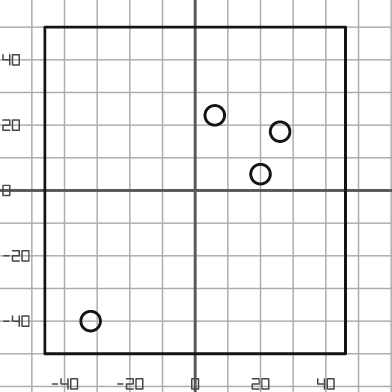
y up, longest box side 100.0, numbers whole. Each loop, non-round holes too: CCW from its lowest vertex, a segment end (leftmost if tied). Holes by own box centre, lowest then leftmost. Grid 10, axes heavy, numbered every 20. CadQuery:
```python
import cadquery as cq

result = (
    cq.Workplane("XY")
    .moveTo(-46.0, -50.0)
    .lineTo(46.0, -50.0)
    .lineTo(46.0, 50.0)
    .lineTo(-46.0, 50.0)
    .close()
    .moveTo(-32.0, -40.0)
    .circle(3.0)
    .moveTo(20.0, 5.0)
    .circle(3.0)
    .moveTo(26.0, 18.0)
    .circle(3.0)
    .moveTo(6.0, 23.0)
    .circle(3.0)
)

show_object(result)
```